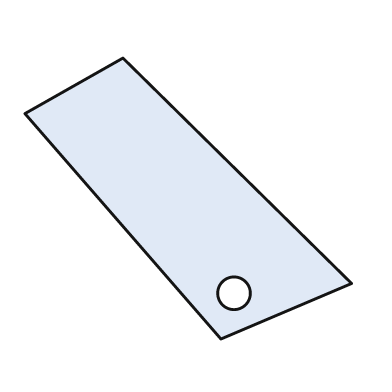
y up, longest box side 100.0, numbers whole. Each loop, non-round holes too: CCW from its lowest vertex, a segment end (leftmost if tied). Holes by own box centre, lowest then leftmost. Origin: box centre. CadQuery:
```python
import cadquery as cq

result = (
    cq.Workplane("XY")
    .moveTo(10.0, -43.0)
    .lineTo(50.0, -26.0)
    .lineTo(-20.0, 43.0)
    .lineTo(-50.0, 26.0)
    .close()
    .moveTo(14.0, -29.0)
    .circle(5.0)
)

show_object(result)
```